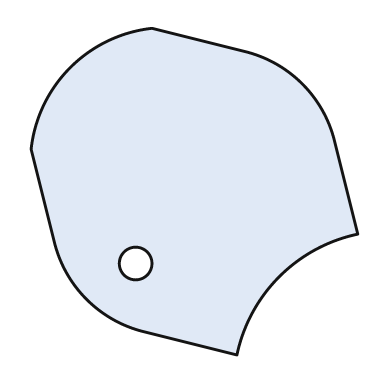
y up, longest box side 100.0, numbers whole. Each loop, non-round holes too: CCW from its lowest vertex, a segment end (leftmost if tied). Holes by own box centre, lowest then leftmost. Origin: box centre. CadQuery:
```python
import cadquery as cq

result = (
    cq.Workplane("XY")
    .moveTo(13.0, -50.0)
    .threePointArc((26.0, -26.0), (50.0, -13.0))
    .lineTo(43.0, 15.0)
    .threePointArc((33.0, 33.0), (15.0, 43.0))
    .lineTo(-13.0, 50.0)
    .threePointArc((-38.0, 38.0), (-50.0, 13.0))
    .lineTo(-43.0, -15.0)
    .threePointArc((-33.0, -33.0), (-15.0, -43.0))
    .close()
    .moveTo(-18.0, -22.0)
    .circle(5.0)
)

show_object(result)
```